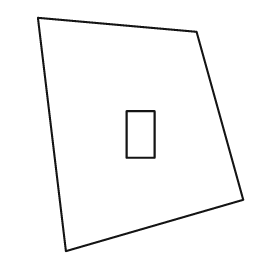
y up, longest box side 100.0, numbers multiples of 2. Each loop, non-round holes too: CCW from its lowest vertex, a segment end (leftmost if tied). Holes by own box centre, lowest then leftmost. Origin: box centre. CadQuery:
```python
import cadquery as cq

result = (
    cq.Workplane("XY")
    .moveTo(-32.0, -50.0)
    .lineTo(44.0, -28.0)
    .lineTo(24.0, 44.0)
    .lineTo(-44.0, 50.0)
    .close()
    .moveTo(-6.0, -10.0)
    .lineTo(6.0, -10.0)
    .lineTo(6.0, 10.0)
    .lineTo(-6.0, 10.0)
    .close()
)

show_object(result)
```